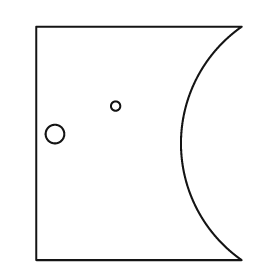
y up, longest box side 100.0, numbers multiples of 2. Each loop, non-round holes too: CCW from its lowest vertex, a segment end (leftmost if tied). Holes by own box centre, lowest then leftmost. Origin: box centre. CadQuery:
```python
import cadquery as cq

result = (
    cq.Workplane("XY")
    .moveTo(-44.0, -50.0)
    .lineTo(44.0, -50.0)
    .threePointArc((18.0, 0.0), (44.0, 50.0))
    .lineTo(-44.0, 50.0)
    .close()
    .moveTo(-36.0, 4.0)
    .circle(4.0)
    .moveTo(-10.0, 16.0)
    .circle(2.0)
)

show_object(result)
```